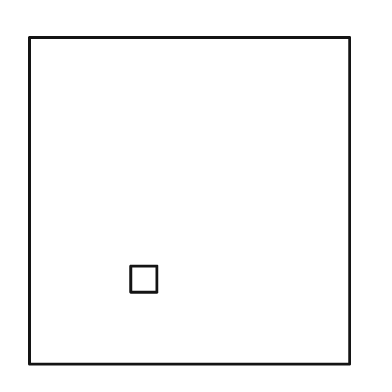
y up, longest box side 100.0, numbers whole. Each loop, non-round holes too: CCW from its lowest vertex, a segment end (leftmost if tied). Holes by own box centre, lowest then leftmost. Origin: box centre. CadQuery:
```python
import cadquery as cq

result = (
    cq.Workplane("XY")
    .moveTo(-49.0, -50.0)
    .lineTo(49.0, -50.0)
    .lineTo(49.0, 50.0)
    .lineTo(-49.0, 50.0)
    .close()
    .moveTo(-18.0, -28.0)
    .lineTo(-10.0, -28.0)
    .lineTo(-10.0, -20.0)
    .lineTo(-18.0, -20.0)
    .close()
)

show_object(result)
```